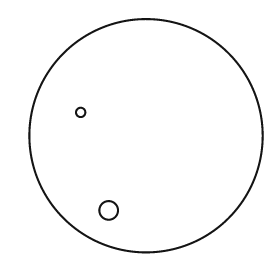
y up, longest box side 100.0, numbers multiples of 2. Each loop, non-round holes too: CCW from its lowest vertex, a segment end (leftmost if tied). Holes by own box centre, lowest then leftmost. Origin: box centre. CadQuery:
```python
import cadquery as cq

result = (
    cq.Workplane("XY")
    .moveTo(0.0, 0.0)
    .circle(50.0)
    .moveTo(-16.0, -32.0)
    .circle(4.0)
    .moveTo(-28.0, 10.0)
    .circle(2.0)
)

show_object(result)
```